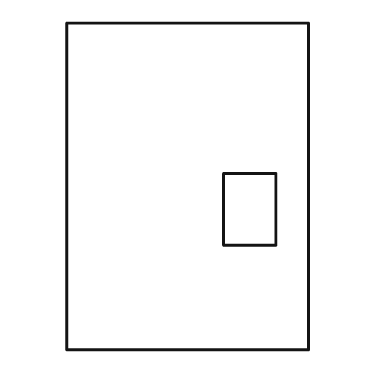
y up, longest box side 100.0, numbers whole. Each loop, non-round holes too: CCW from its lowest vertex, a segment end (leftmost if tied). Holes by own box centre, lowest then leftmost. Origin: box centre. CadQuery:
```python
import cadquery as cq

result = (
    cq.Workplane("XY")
    .moveTo(-37.0, -50.0)
    .lineTo(37.0, -50.0)
    .lineTo(37.0, 50.0)
    .lineTo(-37.0, 50.0)
    .close()
    .moveTo(11.0, -18.0)
    .lineTo(27.0, -18.0)
    .lineTo(27.0, 4.0)
    .lineTo(11.0, 4.0)
    .close()
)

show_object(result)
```